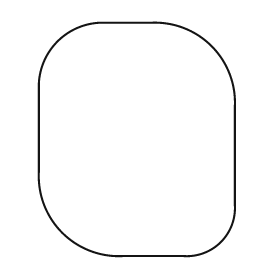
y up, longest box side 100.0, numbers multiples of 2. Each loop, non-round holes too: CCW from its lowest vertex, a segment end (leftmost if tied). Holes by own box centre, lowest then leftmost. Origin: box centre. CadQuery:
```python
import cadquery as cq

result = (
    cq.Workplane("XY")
    .moveTo(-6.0, -50.0)
    .lineTo(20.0, -50.0)
    .threePointArc((36.0, -44.0), (42.0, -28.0))
    .lineTo(42.0, 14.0)
    .threePointArc((32.0, 40.0), (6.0, 50.0))
    .lineTo(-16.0, 50.0)
    .threePointArc((-34.0, 42.0), (-42.0, 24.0))
    .lineTo(-42.0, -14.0)
    .threePointArc((-32.0, -40.0), (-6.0, -50.0))
    .close()
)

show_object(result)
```